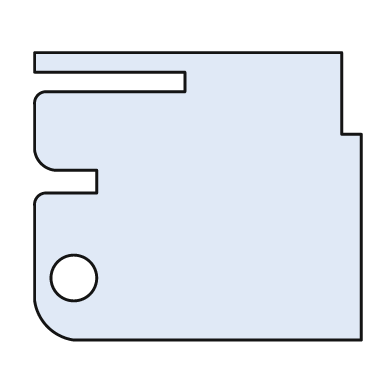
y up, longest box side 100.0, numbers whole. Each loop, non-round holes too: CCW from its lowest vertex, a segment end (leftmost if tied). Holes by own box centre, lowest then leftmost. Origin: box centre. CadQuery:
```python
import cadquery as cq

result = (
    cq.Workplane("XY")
    .moveTo(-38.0, -44.0)
    .lineTo(50.0, -44.0)
    .lineTo(50.0, 19.0)
    .lineTo(44.0, 19.0)
    .lineTo(44.0, 44.0)
    .lineTo(-50.0, 44.0)
    .lineTo(-50.0, 38.0)
    .lineTo(-4.0, 38.0)
    .lineTo(-4.0, 32.0)
    .lineTo(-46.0, 32.0)
    .threePointArc((-49.0, 31.0), (-50.0, 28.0))
    .lineTo(-50.0, 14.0)
    .threePointArc((-48.0, 10.0), (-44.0, 8.0))
    .lineTo(-31.0, 8.0)
    .lineTo(-31.0, 1.0)
    .lineTo(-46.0, 1.0)
    .threePointArc((-49.0, 0.0), (-50.0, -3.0))
    .lineTo(-50.0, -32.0)
    .threePointArc((-46.0, -40.0), (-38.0, -44.0))
    .close()
    .moveTo(-38.0, -25.0)
    .circle(7.0)
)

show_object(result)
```